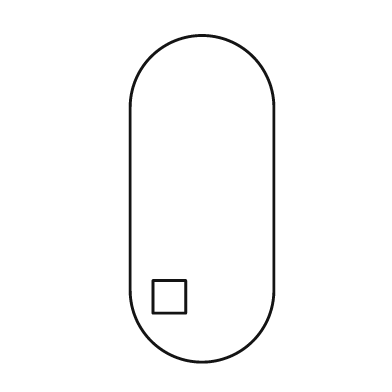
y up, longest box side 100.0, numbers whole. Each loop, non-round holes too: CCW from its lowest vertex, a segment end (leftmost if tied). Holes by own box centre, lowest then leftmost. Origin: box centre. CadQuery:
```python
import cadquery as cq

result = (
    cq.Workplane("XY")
    .moveTo(-22.0, -28.0)
    .threePointArc((0.0, -50.0), (22.0, -28.0))
    .lineTo(22.0, 28.0)
    .threePointArc((0.0, 50.0), (-22.0, 28.0))
    .close()
    .moveTo(-15.0, -35.0)
    .lineTo(-5.0, -35.0)
    .lineTo(-5.0, -25.0)
    .lineTo(-15.0, -25.0)
    .close()
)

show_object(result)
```